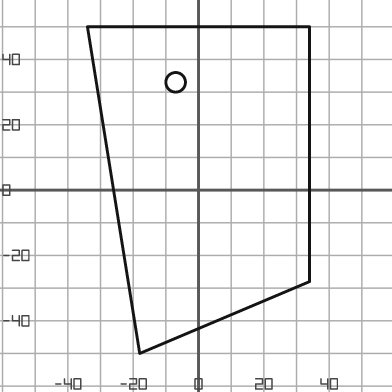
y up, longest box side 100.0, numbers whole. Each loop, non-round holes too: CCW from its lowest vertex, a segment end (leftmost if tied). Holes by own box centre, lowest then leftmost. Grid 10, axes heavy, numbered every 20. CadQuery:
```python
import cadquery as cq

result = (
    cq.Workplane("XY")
    .moveTo(-18.0, -50.0)
    .lineTo(34.0, -28.0)
    .lineTo(34.0, 50.0)
    .lineTo(-34.0, 50.0)
    .close()
    .moveTo(-7.0, 33.0)
    .circle(3.0)
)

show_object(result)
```